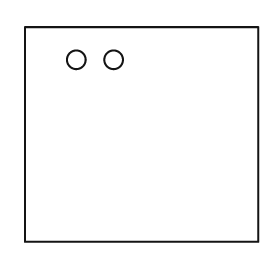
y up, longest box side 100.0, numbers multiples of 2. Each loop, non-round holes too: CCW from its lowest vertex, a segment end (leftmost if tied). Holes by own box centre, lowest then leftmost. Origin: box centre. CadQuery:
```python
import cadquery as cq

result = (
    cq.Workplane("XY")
    .moveTo(-50.0, -46.0)
    .lineTo(50.0, -46.0)
    .lineTo(50.0, 46.0)
    .lineTo(-50.0, 46.0)
    .close()
    .moveTo(-28.0, 32.0)
    .circle(4.0)
    .moveTo(-12.0, 32.0)
    .circle(4.0)
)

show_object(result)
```